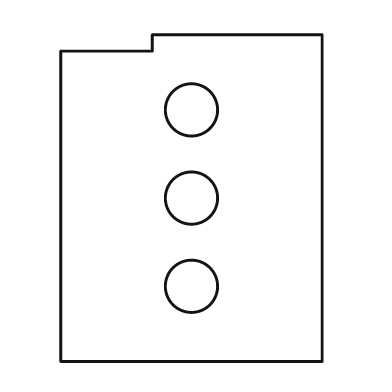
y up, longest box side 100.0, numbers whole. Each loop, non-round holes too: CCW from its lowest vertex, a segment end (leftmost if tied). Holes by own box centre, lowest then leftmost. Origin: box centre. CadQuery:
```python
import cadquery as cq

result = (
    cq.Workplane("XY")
    .moveTo(-40.0, -50.0)
    .lineTo(40.0, -50.0)
    .lineTo(40.0, 50.0)
    .lineTo(-12.0, 50.0)
    .lineTo(-12.0, 45.0)
    .lineTo(-40.0, 45.0)
    .close()
    .moveTo(0.0, -27.0)
    .circle(8.0)
    .moveTo(0.0, 0.0)
    .circle(8.0)
    .moveTo(0.0, 27.0)
    .circle(8.0)
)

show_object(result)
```